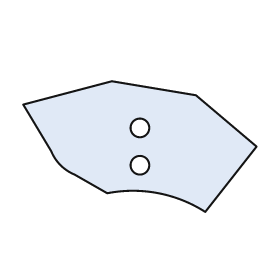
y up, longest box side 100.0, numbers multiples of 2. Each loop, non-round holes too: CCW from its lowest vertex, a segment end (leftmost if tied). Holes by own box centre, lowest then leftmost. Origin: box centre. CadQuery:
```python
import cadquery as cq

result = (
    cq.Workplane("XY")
    .moveTo(28.0, -28.0)
    .lineTo(50.0, 0.0)
    .lineTo(24.0, 22.0)
    .lineTo(-12.0, 28.0)
    .lineTo(-50.0, 18.0)
    .lineTo(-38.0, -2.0)
    .threePointArc((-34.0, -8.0), (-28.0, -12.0))
    .lineTo(-14.0, -20.0)
    .threePointArc((8.0, -20.0), (28.0, -28.0))
    .close()
    .moveTo(0.0, -8.0)
    .circle(4.0)
    .moveTo(0.0, 8.0)
    .circle(4.0)
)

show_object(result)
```